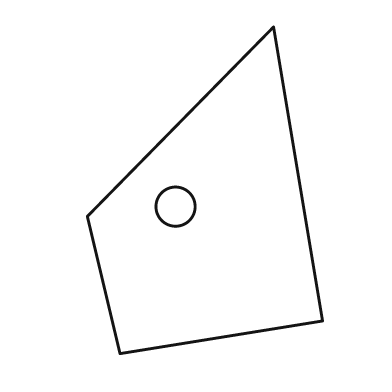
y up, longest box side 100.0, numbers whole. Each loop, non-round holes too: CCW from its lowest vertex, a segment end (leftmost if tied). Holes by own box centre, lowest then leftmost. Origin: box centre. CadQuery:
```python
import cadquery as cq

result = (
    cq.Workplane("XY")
    .moveTo(-26.0, -50.0)
    .lineTo(36.0, -40.0)
    .lineTo(21.0, 50.0)
    .lineTo(-36.0, -8.0)
    .close()
    .moveTo(-9.0, -5.0)
    .circle(6.0)
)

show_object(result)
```